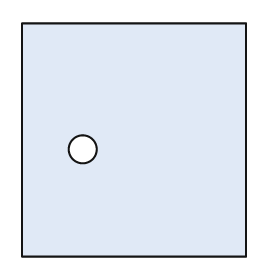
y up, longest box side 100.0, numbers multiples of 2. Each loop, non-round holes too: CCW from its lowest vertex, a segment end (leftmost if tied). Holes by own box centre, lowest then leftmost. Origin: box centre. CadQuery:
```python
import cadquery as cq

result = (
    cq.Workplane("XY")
    .moveTo(-48.0, -50.0)
    .lineTo(48.0, -50.0)
    .lineTo(48.0, 50.0)
    .lineTo(-48.0, 50.0)
    .close()
    .moveTo(-22.0, -4.0)
    .circle(6.0)
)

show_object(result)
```